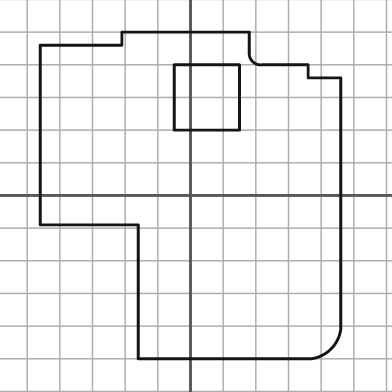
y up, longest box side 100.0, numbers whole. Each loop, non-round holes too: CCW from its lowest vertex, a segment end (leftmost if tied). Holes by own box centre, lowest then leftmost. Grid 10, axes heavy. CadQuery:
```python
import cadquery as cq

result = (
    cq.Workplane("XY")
    .moveTo(-16.0, -50.0)
    .lineTo(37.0, -50.0)
    .threePointArc((43.0, -47.0), (46.0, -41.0))
    .lineTo(46.0, 36.0)
    .lineTo(36.0, 36.0)
    .lineTo(36.0, 40.0)
    .lineTo(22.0, 40.0)
    .threePointArc((19.0, 41.0), (18.0, 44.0))
    .lineTo(18.0, 50.0)
    .lineTo(-21.0, 50.0)
    .lineTo(-21.0, 46.0)
    .lineTo(-46.0, 46.0)
    .lineTo(-46.0, -9.0)
    .lineTo(-16.0, -9.0)
    .close()
    .moveTo(-5.0, 20.0)
    .lineTo(15.0, 20.0)
    .lineTo(15.0, 40.0)
    .lineTo(-5.0, 40.0)
    .close()
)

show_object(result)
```